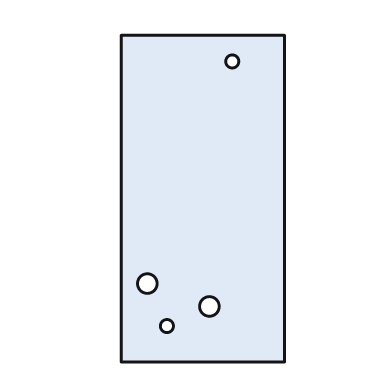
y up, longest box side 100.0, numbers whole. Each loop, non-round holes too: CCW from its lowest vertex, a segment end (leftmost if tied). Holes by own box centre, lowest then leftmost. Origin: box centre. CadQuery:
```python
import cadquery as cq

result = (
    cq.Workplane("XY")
    .moveTo(-25.0, -50.0)
    .lineTo(25.0, -50.0)
    .lineTo(25.0, 50.0)
    .lineTo(-25.0, 50.0)
    .close()
    .moveTo(-11.0, -39.0)
    .circle(2.0)
    .moveTo(2.0, -33.0)
    .circle(3.0)
    .moveTo(-17.0, -26.0)
    .circle(3.0)
    .moveTo(9.0, 42.0)
    .circle(2.0)
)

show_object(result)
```